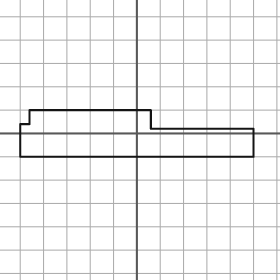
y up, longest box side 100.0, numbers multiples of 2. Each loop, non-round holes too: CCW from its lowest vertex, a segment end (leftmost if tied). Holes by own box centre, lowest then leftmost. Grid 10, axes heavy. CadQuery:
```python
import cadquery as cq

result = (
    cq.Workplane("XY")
    .moveTo(-50.0, -10.0)
    .lineTo(50.0, -10.0)
    .lineTo(50.0, 2.0)
    .lineTo(6.0, 2.0)
    .lineTo(6.0, 10.0)
    .lineTo(-46.0, 10.0)
    .lineTo(-46.0, 4.0)
    .lineTo(-50.0, 4.0)
    .close()
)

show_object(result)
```